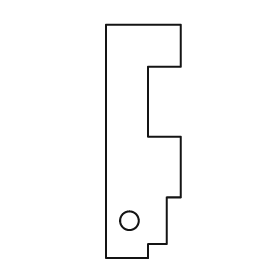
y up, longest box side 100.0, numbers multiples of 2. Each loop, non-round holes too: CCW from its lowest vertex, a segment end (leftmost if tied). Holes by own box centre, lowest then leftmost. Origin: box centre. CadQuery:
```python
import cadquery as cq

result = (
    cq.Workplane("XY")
    .moveTo(-16.0, -50.0)
    .lineTo(2.0, -50.0)
    .lineTo(2.0, -44.0)
    .lineTo(10.0, -44.0)
    .lineTo(10.0, -24.0)
    .lineTo(16.0, -24.0)
    .lineTo(16.0, 2.0)
    .lineTo(2.0, 2.0)
    .lineTo(2.0, 32.0)
    .lineTo(16.0, 32.0)
    .lineTo(16.0, 50.0)
    .lineTo(-16.0, 50.0)
    .close()
    .moveTo(-6.0, -34.0)
    .circle(4.0)
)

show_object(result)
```